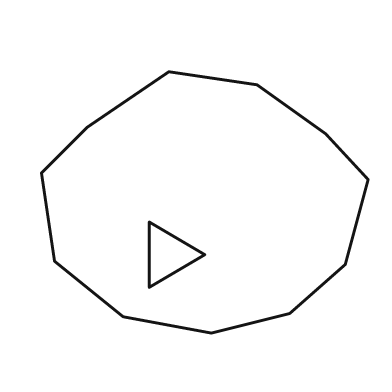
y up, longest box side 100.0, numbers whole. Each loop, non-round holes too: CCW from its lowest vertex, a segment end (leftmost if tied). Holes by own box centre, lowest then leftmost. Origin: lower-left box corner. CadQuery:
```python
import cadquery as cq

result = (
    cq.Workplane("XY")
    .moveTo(52.0, 0.0)
    .lineTo(76.0, 6.0)
    .lineTo(93.0, 21.0)
    .lineTo(100.0, 47.0)
    .lineTo(87.0, 61.0)
    .lineTo(66.0, 76.0)
    .lineTo(39.0, 80.0)
    .lineTo(14.0, 63.0)
    .lineTo(0.0, 49.0)
    .lineTo(4.0, 22.0)
    .lineTo(25.0, 5.0)
    .close()
    .moveTo(33.0, 14.0)
    .lineTo(50.0, 24.0)
    .lineTo(33.0, 34.0)
    .close()
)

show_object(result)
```